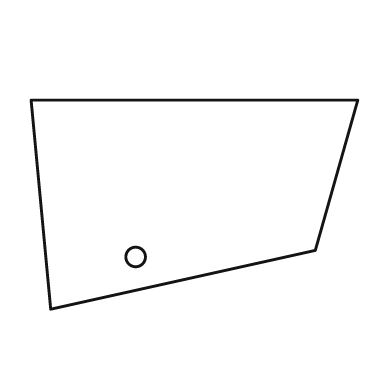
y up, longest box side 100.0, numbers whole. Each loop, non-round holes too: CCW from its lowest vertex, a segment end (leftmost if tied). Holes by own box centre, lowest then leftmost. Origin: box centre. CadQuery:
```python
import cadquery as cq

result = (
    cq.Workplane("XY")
    .moveTo(-44.0, -32.0)
    .lineTo(37.0, -14.0)
    .lineTo(50.0, 32.0)
    .lineTo(-50.0, 32.0)
    .close()
    .moveTo(-18.0, -16.0)
    .circle(3.0)
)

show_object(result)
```